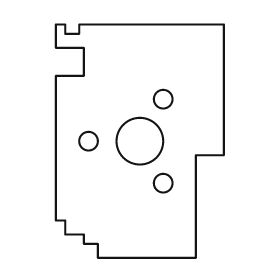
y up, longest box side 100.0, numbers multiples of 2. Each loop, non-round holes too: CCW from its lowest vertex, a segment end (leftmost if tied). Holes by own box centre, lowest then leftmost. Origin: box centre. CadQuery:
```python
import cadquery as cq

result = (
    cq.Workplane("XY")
    .moveTo(-18.0, -50.0)
    .lineTo(24.0, -50.0)
    .lineTo(24.0, -6.0)
    .lineTo(36.0, -6.0)
    .lineTo(36.0, 50.0)
    .lineTo(-26.0, 50.0)
    .lineTo(-26.0, 46.0)
    .lineTo(-32.0, 46.0)
    .lineTo(-32.0, 50.0)
    .lineTo(-36.0, 50.0)
    .lineTo(-36.0, 40.0)
    .lineTo(-24.0, 40.0)
    .lineTo(-24.0, 28.0)
    .lineTo(-36.0, 28.0)
    .lineTo(-36.0, -34.0)
    .lineTo(-32.0, -34.0)
    .lineTo(-32.0, -40.0)
    .lineTo(-24.0, -40.0)
    .lineTo(-24.0, -44.0)
    .lineTo(-18.0, -44.0)
    .close()
    .moveTo(10.0, -18.0)
    .circle(4.0)
    .moveTo(-22.0, 0.0)
    .circle(4.0)
    .moveTo(0.0, 0.0)
    .circle(10.0)
    .moveTo(10.0, 18.0)
    .circle(4.0)
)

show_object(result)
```